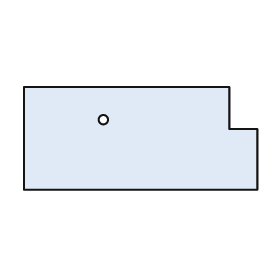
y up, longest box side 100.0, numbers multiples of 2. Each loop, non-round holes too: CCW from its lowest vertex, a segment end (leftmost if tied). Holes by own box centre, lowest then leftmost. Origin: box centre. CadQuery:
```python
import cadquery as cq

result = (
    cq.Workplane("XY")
    .moveTo(-50.0, -22.0)
    .lineTo(50.0, -22.0)
    .lineTo(50.0, 4.0)
    .lineTo(38.0, 4.0)
    .lineTo(38.0, 22.0)
    .lineTo(-50.0, 22.0)
    .close()
    .moveTo(-16.0, 8.0)
    .circle(2.0)
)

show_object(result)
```